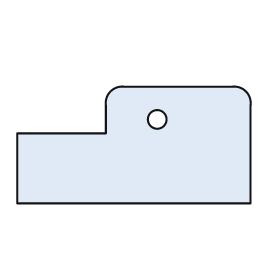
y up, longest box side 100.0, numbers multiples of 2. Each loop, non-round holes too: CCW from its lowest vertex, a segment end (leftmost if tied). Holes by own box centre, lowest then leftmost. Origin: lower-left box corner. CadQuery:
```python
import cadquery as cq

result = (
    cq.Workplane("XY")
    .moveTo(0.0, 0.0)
    .lineTo(100.0, 0.0)
    .lineTo(100.0, 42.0)
    .threePointArc((98.0, 48.0), (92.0, 50.0))
    .lineTo(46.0, 50.0)
    .threePointArc((40.0, 48.0), (38.0, 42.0))
    .lineTo(38.0, 30.0)
    .lineTo(0.0, 30.0)
    .close()
    .moveTo(60.0, 36.0)
    .circle(4.0)
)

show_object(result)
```